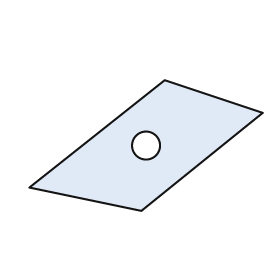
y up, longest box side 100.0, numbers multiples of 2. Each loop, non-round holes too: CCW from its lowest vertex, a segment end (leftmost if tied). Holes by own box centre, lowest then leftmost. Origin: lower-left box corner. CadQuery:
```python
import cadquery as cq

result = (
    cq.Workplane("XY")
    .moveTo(48.0, 0.0)
    .lineTo(100.0, 42.0)
    .lineTo(58.0, 56.0)
    .lineTo(0.0, 10.0)
    .close()
    .moveTo(50.0, 28.0)
    .circle(6.0)
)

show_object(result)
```